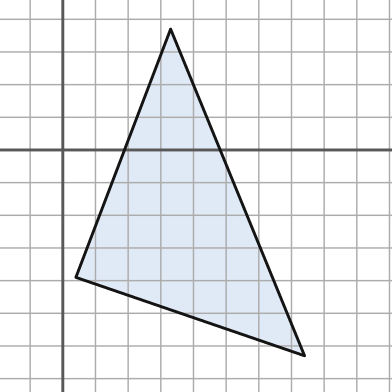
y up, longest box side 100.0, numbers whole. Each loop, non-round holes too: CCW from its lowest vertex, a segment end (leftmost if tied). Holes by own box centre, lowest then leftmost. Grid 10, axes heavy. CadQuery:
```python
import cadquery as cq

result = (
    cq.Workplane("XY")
    .moveTo(74.0, -63.0)
    .lineTo(33.0, 37.0)
    .lineTo(4.0, -39.0)
    .close()
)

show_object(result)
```